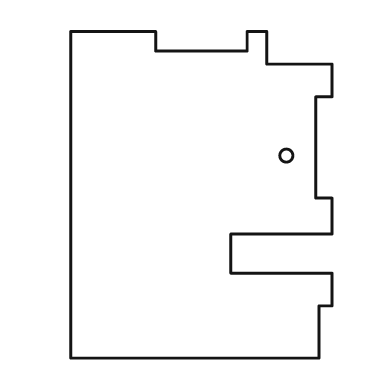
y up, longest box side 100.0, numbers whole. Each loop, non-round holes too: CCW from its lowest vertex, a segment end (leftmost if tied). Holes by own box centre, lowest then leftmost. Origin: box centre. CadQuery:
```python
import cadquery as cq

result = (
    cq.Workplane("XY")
    .moveTo(-40.0, -50.0)
    .lineTo(36.0, -50.0)
    .lineTo(36.0, -34.0)
    .lineTo(40.0, -34.0)
    .lineTo(40.0, -24.0)
    .lineTo(9.0, -24.0)
    .lineTo(9.0, -12.0)
    .lineTo(40.0, -12.0)
    .lineTo(40.0, -1.0)
    .lineTo(35.0, -1.0)
    .lineTo(35.0, 30.0)
    .lineTo(40.0, 30.0)
    .lineTo(40.0, 40.0)
    .lineTo(20.0, 40.0)
    .lineTo(20.0, 50.0)
    .lineTo(14.0, 50.0)
    .lineTo(14.0, 44.0)
    .lineTo(-14.0, 44.0)
    .lineTo(-14.0, 50.0)
    .lineTo(-40.0, 50.0)
    .close()
    .moveTo(26.0, 12.0)
    .circle(2.0)
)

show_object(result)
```